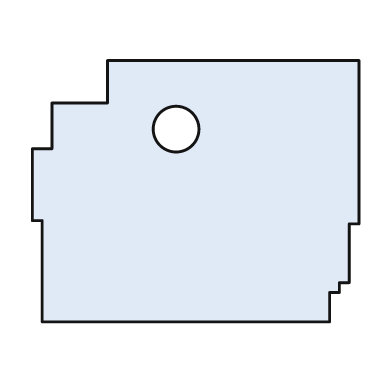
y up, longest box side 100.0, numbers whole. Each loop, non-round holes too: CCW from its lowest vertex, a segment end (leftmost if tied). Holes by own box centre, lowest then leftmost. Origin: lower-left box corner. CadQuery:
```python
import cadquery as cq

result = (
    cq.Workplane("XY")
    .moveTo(3.0, 0.0)
    .lineTo(91.0, 0.0)
    .lineTo(91.0, 9.0)
    .lineTo(94.0, 9.0)
    .lineTo(94.0, 12.0)
    .lineTo(97.0, 12.0)
    .lineTo(97.0, 30.0)
    .lineTo(100.0, 30.0)
    .lineTo(100.0, 80.0)
    .lineTo(23.0, 80.0)
    .lineTo(23.0, 67.0)
    .lineTo(6.0, 67.0)
    .lineTo(6.0, 53.0)
    .lineTo(0.0, 53.0)
    .lineTo(0.0, 31.0)
    .lineTo(3.0, 31.0)
    .close()
    .moveTo(44.0, 59.0)
    .circle(7.0)
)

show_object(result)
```